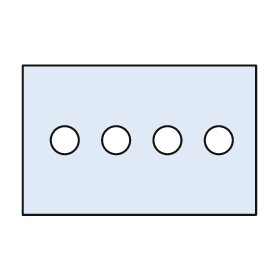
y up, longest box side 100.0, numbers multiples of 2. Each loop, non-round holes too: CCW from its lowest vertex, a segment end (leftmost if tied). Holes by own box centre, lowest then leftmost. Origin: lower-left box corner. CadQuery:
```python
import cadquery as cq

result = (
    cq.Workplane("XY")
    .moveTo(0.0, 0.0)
    .lineTo(100.0, 0.0)
    .lineTo(100.0, 64.0)
    .lineTo(0.0, 64.0)
    .close()
    .moveTo(18.0, 32.0)
    .circle(6.0)
    .moveTo(40.0, 32.0)
    .circle(6.0)
    .moveTo(62.0, 32.0)
    .circle(6.0)
    .moveTo(84.0, 32.0)
    .circle(6.0)
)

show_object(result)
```